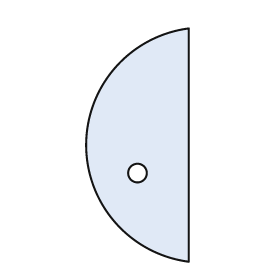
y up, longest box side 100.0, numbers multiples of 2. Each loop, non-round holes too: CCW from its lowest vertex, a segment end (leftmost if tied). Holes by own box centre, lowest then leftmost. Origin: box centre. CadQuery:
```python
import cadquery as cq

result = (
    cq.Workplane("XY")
    .moveTo(22.0, -50.0)
    .lineTo(22.0, 50.0)
    .threePointArc((-22.0, 0.0), (22.0, -50.0))
    .close()
    .moveTo(0.0, -12.0)
    .circle(4.0)
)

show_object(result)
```